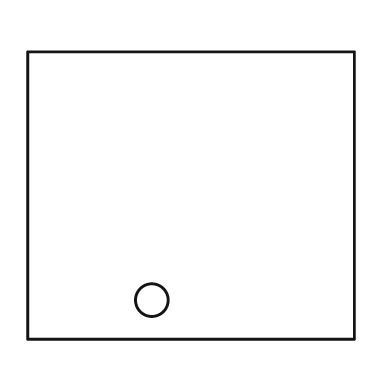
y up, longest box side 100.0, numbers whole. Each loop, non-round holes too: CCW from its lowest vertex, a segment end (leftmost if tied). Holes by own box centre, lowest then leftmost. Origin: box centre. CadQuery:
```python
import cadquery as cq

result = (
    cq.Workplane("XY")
    .moveTo(-50.0, -44.0)
    .lineTo(50.0, -44.0)
    .lineTo(50.0, 44.0)
    .lineTo(-50.0, 44.0)
    .close()
    .moveTo(-12.0, -32.0)
    .circle(5.0)
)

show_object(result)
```